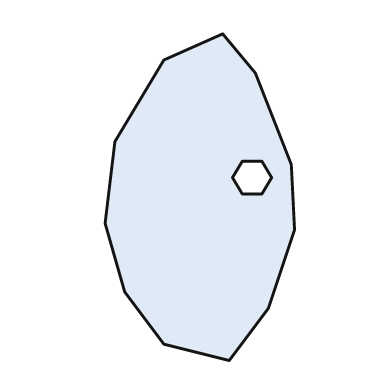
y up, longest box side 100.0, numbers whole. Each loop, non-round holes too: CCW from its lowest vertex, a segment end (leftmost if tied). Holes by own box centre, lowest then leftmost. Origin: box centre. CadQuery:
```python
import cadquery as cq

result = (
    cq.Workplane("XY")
    .moveTo(9.0, -50.0)
    .lineTo(21.0, -34.0)
    .lineTo(29.0, -10.0)
    .lineTo(28.0, 10.0)
    .lineTo(17.0, 38.0)
    .lineTo(7.0, 50.0)
    .lineTo(-11.0, 42.0)
    .lineTo(-26.0, 17.0)
    .lineTo(-29.0, -8.0)
    .lineTo(-23.0, -29.0)
    .lineTo(-11.0, -45.0)
    .close()
    .moveTo(13.0, 1.0)
    .lineTo(19.0, 1.0)
    .lineTo(22.0, 6.0)
    .lineTo(19.0, 11.0)
    .lineTo(13.0, 11.0)
    .lineTo(10.0, 6.0)
    .close()
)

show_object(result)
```